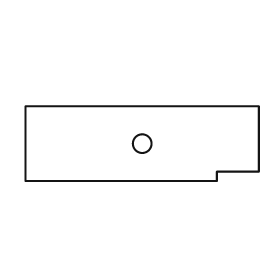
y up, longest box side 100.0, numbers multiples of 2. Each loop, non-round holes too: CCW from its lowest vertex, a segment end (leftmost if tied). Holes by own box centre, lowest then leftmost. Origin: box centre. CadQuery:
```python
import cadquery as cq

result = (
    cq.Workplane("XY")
    .moveTo(-50.0, -16.0)
    .lineTo(32.0, -16.0)
    .lineTo(32.0, -12.0)
    .lineTo(50.0, -12.0)
    .lineTo(50.0, 16.0)
    .lineTo(-50.0, 16.0)
    .close()
    .moveTo(0.0, 0.0)
    .circle(4.0)
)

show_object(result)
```